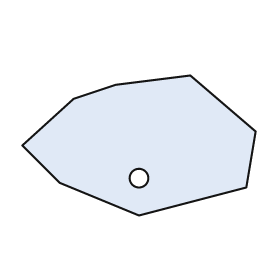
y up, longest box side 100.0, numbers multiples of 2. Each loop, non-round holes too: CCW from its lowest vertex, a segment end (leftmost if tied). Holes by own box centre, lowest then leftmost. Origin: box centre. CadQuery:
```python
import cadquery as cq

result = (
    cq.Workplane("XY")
    .moveTo(0.0, -30.0)
    .lineTo(46.0, -18.0)
    .lineTo(50.0, 6.0)
    .lineTo(22.0, 30.0)
    .lineTo(-10.0, 26.0)
    .lineTo(-28.0, 20.0)
    .lineTo(-50.0, 0.0)
    .lineTo(-34.0, -16.0)
    .close()
    .moveTo(0.0, -14.0)
    .circle(4.0)
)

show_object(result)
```